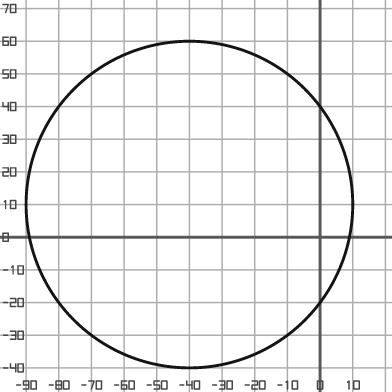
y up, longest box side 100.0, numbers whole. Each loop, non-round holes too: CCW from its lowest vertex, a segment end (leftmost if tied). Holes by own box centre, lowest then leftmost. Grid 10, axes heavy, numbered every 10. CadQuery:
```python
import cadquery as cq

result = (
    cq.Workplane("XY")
    .moveTo(-40.0, 10.0)
    .circle(50.0)
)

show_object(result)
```